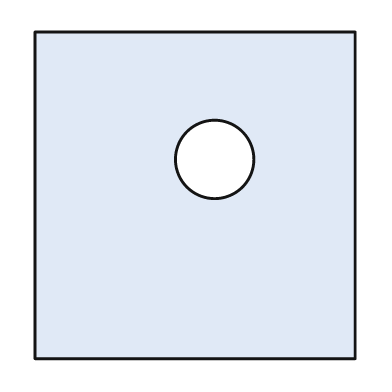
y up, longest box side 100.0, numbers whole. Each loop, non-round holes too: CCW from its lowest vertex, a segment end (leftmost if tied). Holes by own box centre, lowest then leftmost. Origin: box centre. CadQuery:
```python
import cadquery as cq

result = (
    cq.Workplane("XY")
    .moveTo(-49.0, -50.0)
    .lineTo(49.0, -50.0)
    .lineTo(49.0, 50.0)
    .lineTo(-49.0, 50.0)
    .close()
    .moveTo(6.0, 11.0)
    .circle(12.0)
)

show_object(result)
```